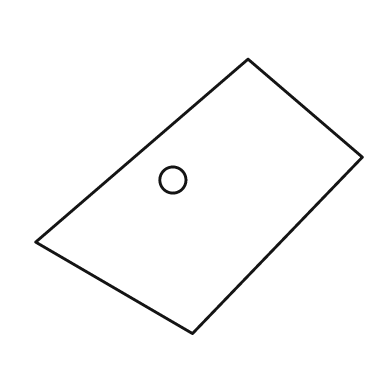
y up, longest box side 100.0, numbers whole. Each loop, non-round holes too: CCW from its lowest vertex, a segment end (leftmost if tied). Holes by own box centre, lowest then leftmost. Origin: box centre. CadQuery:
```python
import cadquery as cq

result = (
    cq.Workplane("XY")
    .moveTo(-2.0, -42.0)
    .lineTo(50.0, 12.0)
    .lineTo(15.0, 42.0)
    .lineTo(-50.0, -14.0)
    .close()
    .moveTo(-8.0, 5.0)
    .circle(4.0)
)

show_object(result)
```